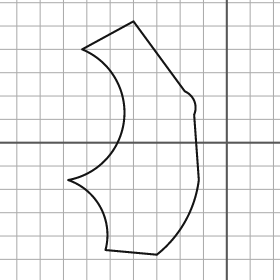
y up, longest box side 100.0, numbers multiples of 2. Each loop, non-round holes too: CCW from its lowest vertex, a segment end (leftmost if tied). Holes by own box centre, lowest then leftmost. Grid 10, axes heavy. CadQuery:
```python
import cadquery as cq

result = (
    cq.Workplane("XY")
    .moveTo(-30.0, -48.0)
    .threePointArc((-18.0, -34.0), (-12.0, -16.0))
    .lineTo(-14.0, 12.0)
    .threePointArc((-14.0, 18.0), (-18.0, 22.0))
    .lineTo(-40.0, 52.0)
    .lineTo(-62.0, 40.0)
    .threePointArc((-44.0, 10.0), (-68.0, -16.0))
    .threePointArc((-54.0, -28.0), (-52.0, -46.0))
    .close()
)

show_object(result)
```